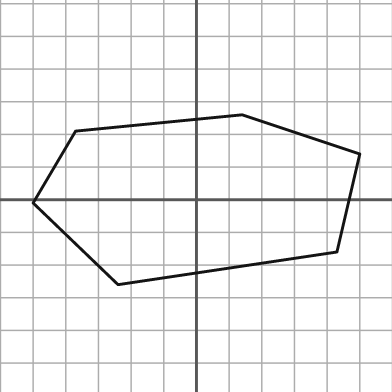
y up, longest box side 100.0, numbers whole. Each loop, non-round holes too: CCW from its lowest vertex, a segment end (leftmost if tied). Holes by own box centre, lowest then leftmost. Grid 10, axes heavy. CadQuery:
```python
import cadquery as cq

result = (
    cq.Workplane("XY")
    .moveTo(-24.0, -26.0)
    .lineTo(43.0, -16.0)
    .lineTo(50.0, 14.0)
    .lineTo(14.0, 26.0)
    .lineTo(-37.0, 21.0)
    .lineTo(-50.0, -1.0)
    .close()
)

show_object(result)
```